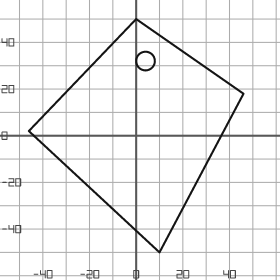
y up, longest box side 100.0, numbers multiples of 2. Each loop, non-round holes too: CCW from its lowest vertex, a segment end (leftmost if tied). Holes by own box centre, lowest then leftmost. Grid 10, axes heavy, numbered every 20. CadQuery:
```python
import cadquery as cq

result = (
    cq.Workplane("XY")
    .moveTo(10.0, -50.0)
    .lineTo(46.0, 18.0)
    .lineTo(0.0, 50.0)
    .lineTo(-46.0, 2.0)
    .close()
    .moveTo(4.0, 32.0)
    .circle(4.0)
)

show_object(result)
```